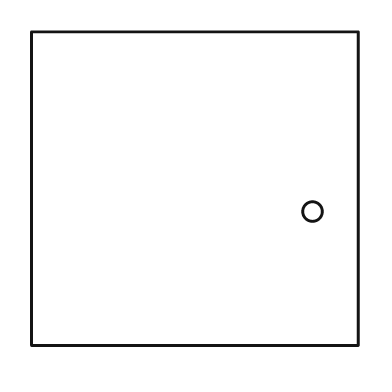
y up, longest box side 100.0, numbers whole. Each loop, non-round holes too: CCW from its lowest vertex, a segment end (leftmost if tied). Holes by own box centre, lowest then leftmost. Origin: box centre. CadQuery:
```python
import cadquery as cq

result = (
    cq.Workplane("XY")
    .moveTo(-50.0, -48.0)
    .lineTo(50.0, -48.0)
    .lineTo(50.0, 48.0)
    .lineTo(-50.0, 48.0)
    .close()
    .moveTo(36.0, -7.0)
    .circle(3.0)
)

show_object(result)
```